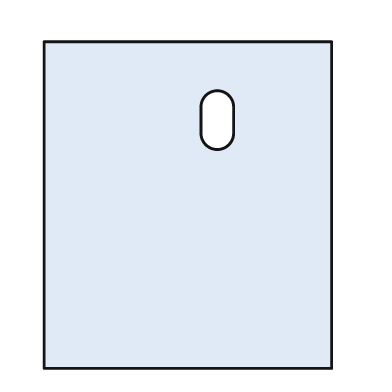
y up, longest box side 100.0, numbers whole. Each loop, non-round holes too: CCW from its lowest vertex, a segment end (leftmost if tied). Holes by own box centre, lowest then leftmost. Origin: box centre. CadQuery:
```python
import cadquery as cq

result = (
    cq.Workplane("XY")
    .moveTo(-44.0, -50.0)
    .lineTo(44.0, -50.0)
    .lineTo(44.0, 50.0)
    .lineTo(-44.0, 50.0)
    .close()
    .moveTo(4.0, 22.0)
    .threePointArc((9.0, 17.0), (14.0, 22.0))
    .lineTo(14.0, 30.0)
    .threePointArc((9.0, 35.0), (4.0, 30.0))
    .close()
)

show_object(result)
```